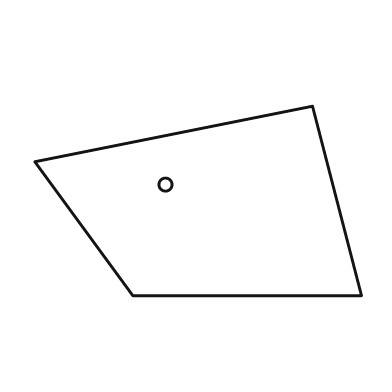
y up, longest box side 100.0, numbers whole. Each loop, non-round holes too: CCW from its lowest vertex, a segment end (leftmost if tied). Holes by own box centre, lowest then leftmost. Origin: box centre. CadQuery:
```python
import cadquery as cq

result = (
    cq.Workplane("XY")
    .moveTo(-20.0, -29.0)
    .lineTo(50.0, -29.0)
    .lineTo(35.0, 29.0)
    .lineTo(-50.0, 12.0)
    .close()
    .moveTo(-10.0, 5.0)
    .circle(2.0)
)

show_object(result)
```